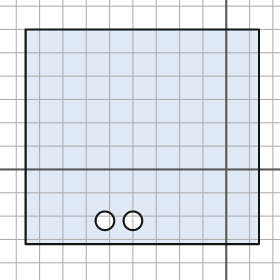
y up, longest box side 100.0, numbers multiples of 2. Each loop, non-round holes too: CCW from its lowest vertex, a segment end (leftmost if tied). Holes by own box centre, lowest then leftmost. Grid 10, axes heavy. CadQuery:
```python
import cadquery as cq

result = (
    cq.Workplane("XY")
    .moveTo(-86.0, -32.0)
    .lineTo(14.0, -32.0)
    .lineTo(14.0, 60.0)
    .lineTo(-86.0, 60.0)
    .close()
    .moveTo(-52.0, -22.0)
    .circle(4.0)
    .moveTo(-40.0, -22.0)
    .circle(4.0)
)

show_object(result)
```